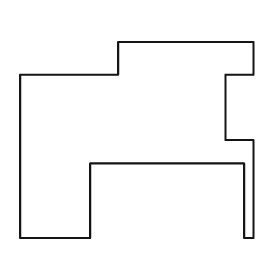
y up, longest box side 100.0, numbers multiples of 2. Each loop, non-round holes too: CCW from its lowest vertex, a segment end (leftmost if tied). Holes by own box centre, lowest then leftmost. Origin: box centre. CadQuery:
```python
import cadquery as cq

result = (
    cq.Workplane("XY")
    .moveTo(-50.0, -42.0)
    .lineTo(-20.0, -42.0)
    .lineTo(-20.0, -10.0)
    .lineTo(46.0, -10.0)
    .lineTo(46.0, -42.0)
    .lineTo(50.0, -42.0)
    .lineTo(50.0, 0.0)
    .lineTo(38.0, 0.0)
    .lineTo(38.0, 28.0)
    .lineTo(50.0, 28.0)
    .lineTo(50.0, 42.0)
    .lineTo(-8.0, 42.0)
    .lineTo(-8.0, 28.0)
    .lineTo(-50.0, 28.0)
    .close()
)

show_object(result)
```